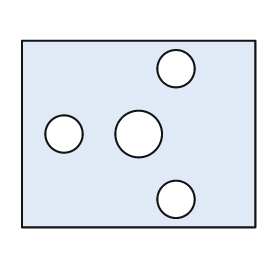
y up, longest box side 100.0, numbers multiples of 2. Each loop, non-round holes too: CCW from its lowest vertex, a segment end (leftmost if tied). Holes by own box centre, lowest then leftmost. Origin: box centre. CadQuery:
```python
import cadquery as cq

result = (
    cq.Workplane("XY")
    .moveTo(-50.0, -40.0)
    .lineTo(50.0, -40.0)
    .lineTo(50.0, 40.0)
    .lineTo(-50.0, 40.0)
    .close()
    .moveTo(16.0, -28.0)
    .circle(8.0)
    .moveTo(-32.0, 0.0)
    .circle(8.0)
    .moveTo(0.0, 0.0)
    .circle(10.0)
    .moveTo(16.0, 28.0)
    .circle(8.0)
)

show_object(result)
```